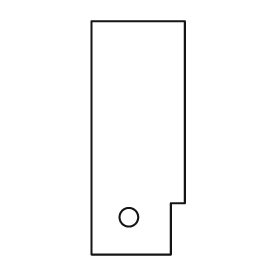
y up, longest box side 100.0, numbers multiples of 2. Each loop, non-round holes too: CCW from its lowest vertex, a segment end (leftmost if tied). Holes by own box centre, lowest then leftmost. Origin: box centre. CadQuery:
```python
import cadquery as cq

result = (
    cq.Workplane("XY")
    .moveTo(-20.0, -50.0)
    .lineTo(14.0, -50.0)
    .lineTo(14.0, -28.0)
    .lineTo(20.0, -28.0)
    .lineTo(20.0, 50.0)
    .lineTo(-20.0, 50.0)
    .close()
    .moveTo(-4.0, -34.0)
    .circle(4.0)
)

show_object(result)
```